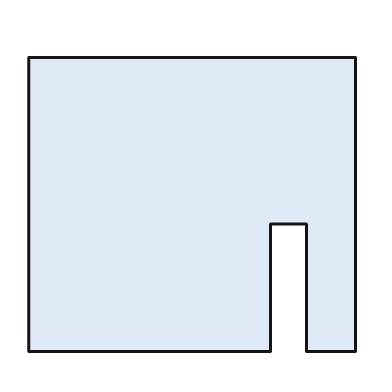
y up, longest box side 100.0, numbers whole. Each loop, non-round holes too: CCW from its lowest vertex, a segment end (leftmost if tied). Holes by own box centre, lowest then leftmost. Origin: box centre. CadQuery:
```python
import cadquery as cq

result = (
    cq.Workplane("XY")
    .moveTo(-50.0, -45.0)
    .lineTo(24.0, -45.0)
    .lineTo(24.0, -6.0)
    .lineTo(35.0, -6.0)
    .lineTo(35.0, -45.0)
    .lineTo(50.0, -45.0)
    .lineTo(50.0, 45.0)
    .lineTo(-50.0, 45.0)
    .close()
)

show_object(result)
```